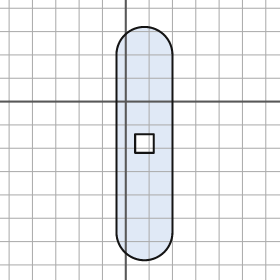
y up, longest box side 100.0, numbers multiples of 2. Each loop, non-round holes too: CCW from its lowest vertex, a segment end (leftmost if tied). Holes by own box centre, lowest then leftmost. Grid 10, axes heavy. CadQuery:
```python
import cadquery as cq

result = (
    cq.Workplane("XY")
    .moveTo(-4.0, -56.0)
    .threePointArc((8.0, -68.0), (20.0, -56.0))
    .lineTo(20.0, 20.0)
    .threePointArc((8.0, 32.0), (-4.0, 20.0))
    .close()
    .moveTo(4.0, -22.0)
    .lineTo(12.0, -22.0)
    .lineTo(12.0, -14.0)
    .lineTo(4.0, -14.0)
    .close()
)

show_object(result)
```